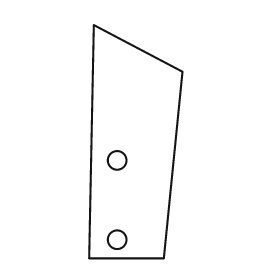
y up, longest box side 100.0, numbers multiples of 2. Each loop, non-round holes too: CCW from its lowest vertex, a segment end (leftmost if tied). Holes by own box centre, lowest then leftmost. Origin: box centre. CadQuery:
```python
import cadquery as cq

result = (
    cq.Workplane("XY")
    .moveTo(-20.0, -50.0)
    .lineTo(12.0, -50.0)
    .lineTo(20.0, 30.0)
    .lineTo(-18.0, 50.0)
    .close()
    .moveTo(-8.0, -42.0)
    .circle(4.0)
    .moveTo(-8.0, -8.0)
    .circle(4.0)
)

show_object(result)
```